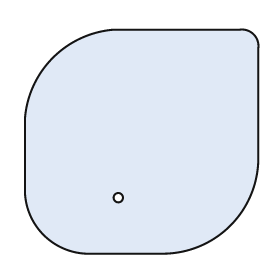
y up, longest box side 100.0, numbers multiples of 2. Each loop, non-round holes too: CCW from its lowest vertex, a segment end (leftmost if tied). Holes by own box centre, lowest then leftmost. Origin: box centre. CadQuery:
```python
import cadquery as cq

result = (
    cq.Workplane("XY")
    .moveTo(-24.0, -48.0)
    .lineTo(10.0, -48.0)
    .threePointArc((38.0, -36.0), (50.0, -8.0))
    .lineTo(50.0, 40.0)
    .threePointArc((48.0, 46.0), (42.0, 48.0))
    .lineTo(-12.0, 48.0)
    .threePointArc((-38.0, 36.0), (-50.0, 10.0))
    .lineTo(-50.0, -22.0)
    .threePointArc((-42.0, -40.0), (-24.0, -48.0))
    .close()
    .moveTo(-10.0, -24.0)
    .circle(2.0)
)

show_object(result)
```